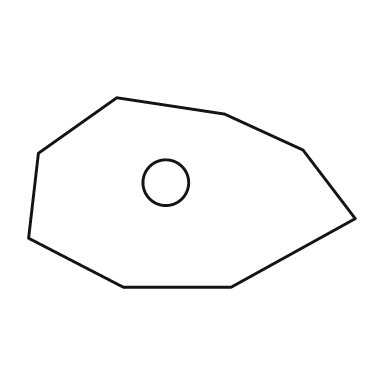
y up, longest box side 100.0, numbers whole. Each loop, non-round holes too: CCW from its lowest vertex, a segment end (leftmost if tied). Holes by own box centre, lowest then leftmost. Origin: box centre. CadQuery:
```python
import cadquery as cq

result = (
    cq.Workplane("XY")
    .moveTo(-21.0, -29.0)
    .lineTo(12.0, -29.0)
    .lineTo(50.0, -8.0)
    .lineTo(34.0, 13.0)
    .lineTo(10.0, 24.0)
    .lineTo(-23.0, 29.0)
    .lineTo(-47.0, 12.0)
    .lineTo(-50.0, -14.0)
    .close()
    .moveTo(-8.0, 3.0)
    .circle(7.0)
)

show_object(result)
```